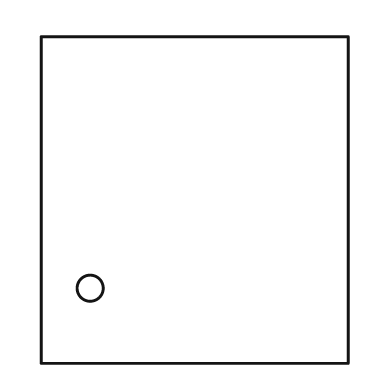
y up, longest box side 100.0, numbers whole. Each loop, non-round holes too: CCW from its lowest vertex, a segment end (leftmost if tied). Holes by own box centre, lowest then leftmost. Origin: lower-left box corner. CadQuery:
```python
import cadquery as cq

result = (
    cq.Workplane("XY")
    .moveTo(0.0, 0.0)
    .lineTo(94.0, 0.0)
    .lineTo(94.0, 100.0)
    .lineTo(0.0, 100.0)
    .close()
    .moveTo(15.0, 23.0)
    .circle(4.0)
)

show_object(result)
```